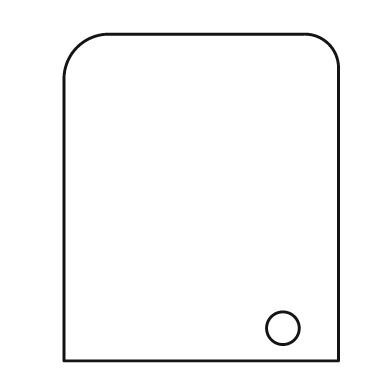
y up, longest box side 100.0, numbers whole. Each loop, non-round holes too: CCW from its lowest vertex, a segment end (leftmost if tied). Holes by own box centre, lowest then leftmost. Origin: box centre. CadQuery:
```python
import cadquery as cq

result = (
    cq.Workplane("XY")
    .moveTo(-42.0, -50.0)
    .lineTo(42.0, -50.0)
    .lineTo(42.0, 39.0)
    .threePointArc((39.0, 47.0), (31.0, 50.0))
    .lineTo(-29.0, 50.0)
    .threePointArc((-38.0, 46.0), (-42.0, 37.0))
    .close()
    .moveTo(25.0, -40.0)
    .circle(5.0)
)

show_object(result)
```